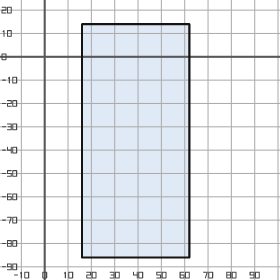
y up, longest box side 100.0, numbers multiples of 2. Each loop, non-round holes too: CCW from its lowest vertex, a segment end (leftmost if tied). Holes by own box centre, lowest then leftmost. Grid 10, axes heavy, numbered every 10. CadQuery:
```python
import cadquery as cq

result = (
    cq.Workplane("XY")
    .moveTo(16.0, -86.0)
    .lineTo(62.0, -86.0)
    .lineTo(62.0, 14.0)
    .lineTo(16.0, 14.0)
    .close()
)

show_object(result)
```